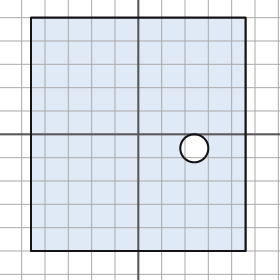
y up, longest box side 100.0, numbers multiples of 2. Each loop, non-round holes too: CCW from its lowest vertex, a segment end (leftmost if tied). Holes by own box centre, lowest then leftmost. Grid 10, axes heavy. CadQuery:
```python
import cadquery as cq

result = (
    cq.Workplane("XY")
    .moveTo(-46.0, -50.0)
    .lineTo(46.0, -50.0)
    .lineTo(46.0, 50.0)
    .lineTo(-46.0, 50.0)
    .close()
    .moveTo(24.0, -6.0)
    .circle(6.0)
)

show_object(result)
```